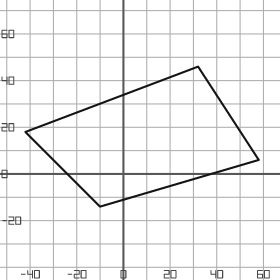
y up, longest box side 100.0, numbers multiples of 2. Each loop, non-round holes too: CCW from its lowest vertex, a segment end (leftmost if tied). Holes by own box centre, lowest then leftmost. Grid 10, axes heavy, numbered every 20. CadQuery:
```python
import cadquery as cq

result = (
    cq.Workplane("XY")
    .moveTo(-10.0, -14.0)
    .lineTo(58.0, 6.0)
    .lineTo(32.0, 46.0)
    .lineTo(-42.0, 18.0)
    .close()
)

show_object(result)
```